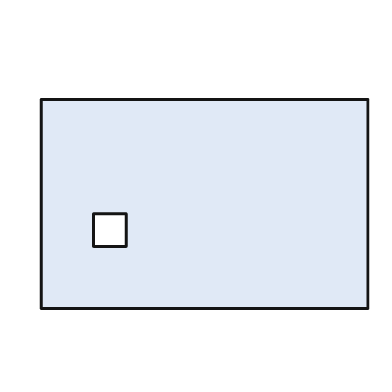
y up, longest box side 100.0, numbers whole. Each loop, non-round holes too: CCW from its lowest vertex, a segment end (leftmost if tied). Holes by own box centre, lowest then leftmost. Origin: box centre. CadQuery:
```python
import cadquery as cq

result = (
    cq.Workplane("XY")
    .moveTo(-50.0, -32.0)
    .lineTo(50.0, -32.0)
    .lineTo(50.0, 32.0)
    .lineTo(-50.0, 32.0)
    .close()
    .moveTo(-34.0, -13.0)
    .lineTo(-24.0, -13.0)
    .lineTo(-24.0, -3.0)
    .lineTo(-34.0, -3.0)
    .close()
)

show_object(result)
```